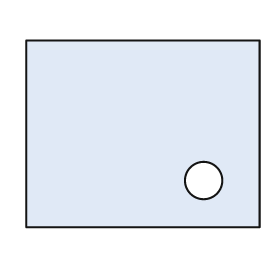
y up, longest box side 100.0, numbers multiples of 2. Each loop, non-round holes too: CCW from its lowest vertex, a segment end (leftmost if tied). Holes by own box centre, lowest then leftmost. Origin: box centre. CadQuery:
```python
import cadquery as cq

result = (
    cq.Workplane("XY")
    .moveTo(-50.0, -40.0)
    .lineTo(50.0, -40.0)
    .lineTo(50.0, 40.0)
    .lineTo(-50.0, 40.0)
    .close()
    .moveTo(26.0, -20.0)
    .circle(8.0)
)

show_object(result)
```